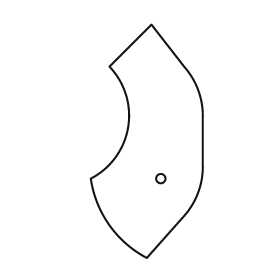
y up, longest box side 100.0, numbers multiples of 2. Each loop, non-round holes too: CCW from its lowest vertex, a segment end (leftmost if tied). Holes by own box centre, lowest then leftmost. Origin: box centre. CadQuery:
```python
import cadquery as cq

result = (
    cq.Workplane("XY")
    .moveTo(0.0, -50.0)
    .lineTo(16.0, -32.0)
    .threePointArc((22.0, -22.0), (24.0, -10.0))
    .lineTo(24.0, 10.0)
    .threePointArc((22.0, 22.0), (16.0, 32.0))
    .lineTo(2.0, 50.0)
    .lineTo(-16.0, 32.0)
    .threePointArc((-8.0, 6.0), (-24.0, -16.0))
    .threePointArc((-16.0, -36.0), (0.0, -50.0))
    .close()
    .moveTo(6.0, -16.0)
    .circle(2.0)
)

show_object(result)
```